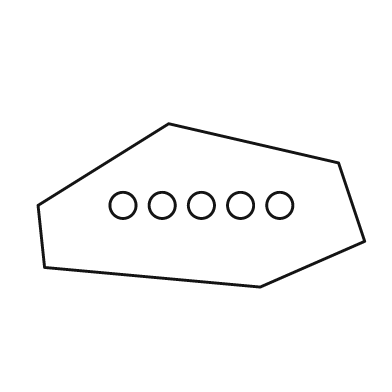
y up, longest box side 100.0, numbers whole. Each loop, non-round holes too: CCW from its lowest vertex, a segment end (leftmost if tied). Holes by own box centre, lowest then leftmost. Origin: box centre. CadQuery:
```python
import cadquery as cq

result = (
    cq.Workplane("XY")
    .moveTo(18.0, -25.0)
    .lineTo(50.0, -11.0)
    .lineTo(42.0, 13.0)
    .lineTo(-10.0, 25.0)
    .lineTo(-50.0, 0.0)
    .lineTo(-48.0, -19.0)
    .close()
    .moveTo(-24.0, 0.0)
    .circle(4.0)
    .moveTo(-12.0, 0.0)
    .circle(4.0)
    .moveTo(0.0, 0.0)
    .circle(4.0)
    .moveTo(12.0, 0.0)
    .circle(4.0)
    .moveTo(24.0, 0.0)
    .circle(4.0)
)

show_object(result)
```